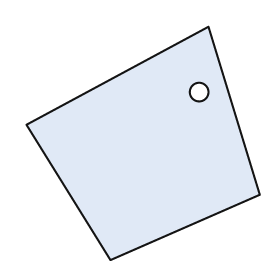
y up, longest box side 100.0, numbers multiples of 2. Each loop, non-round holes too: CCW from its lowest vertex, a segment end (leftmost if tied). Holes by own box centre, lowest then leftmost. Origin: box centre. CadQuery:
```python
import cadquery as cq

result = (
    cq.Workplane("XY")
    .moveTo(-14.0, -50.0)
    .lineTo(50.0, -22.0)
    .lineTo(28.0, 50.0)
    .lineTo(-50.0, 8.0)
    .close()
    .moveTo(24.0, 22.0)
    .circle(4.0)
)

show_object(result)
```